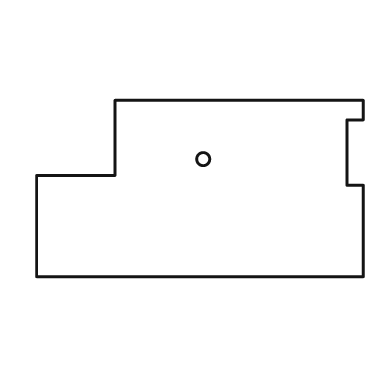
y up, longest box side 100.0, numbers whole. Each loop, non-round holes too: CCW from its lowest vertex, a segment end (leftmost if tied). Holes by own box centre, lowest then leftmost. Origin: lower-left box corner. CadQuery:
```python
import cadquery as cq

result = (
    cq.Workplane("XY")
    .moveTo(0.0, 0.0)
    .lineTo(100.0, 0.0)
    .lineTo(100.0, 28.0)
    .lineTo(95.0, 28.0)
    .lineTo(95.0, 48.0)
    .lineTo(100.0, 48.0)
    .lineTo(100.0, 54.0)
    .lineTo(24.0, 54.0)
    .lineTo(24.0, 31.0)
    .lineTo(0.0, 31.0)
    .close()
    .moveTo(51.0, 36.0)
    .circle(2.0)
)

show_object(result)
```